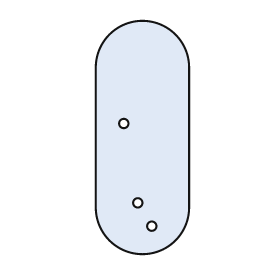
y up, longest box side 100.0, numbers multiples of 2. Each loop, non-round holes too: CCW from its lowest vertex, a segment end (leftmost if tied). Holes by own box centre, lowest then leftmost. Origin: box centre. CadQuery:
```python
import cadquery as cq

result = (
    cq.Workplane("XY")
    .moveTo(-20.0, -30.0)
    .threePointArc((0.0, -50.0), (20.0, -30.0))
    .lineTo(20.0, 30.0)
    .threePointArc((0.0, 50.0), (-20.0, 30.0))
    .close()
    .moveTo(4.0, -38.0)
    .circle(2.0)
    .moveTo(-2.0, -28.0)
    .circle(2.0)
    .moveTo(-8.0, 6.0)
    .circle(2.0)
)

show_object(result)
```